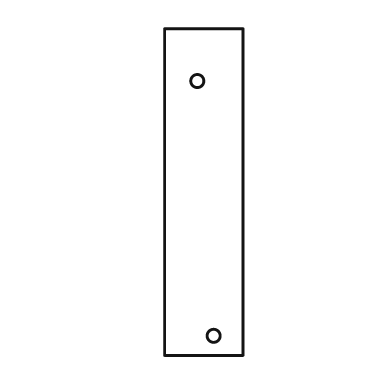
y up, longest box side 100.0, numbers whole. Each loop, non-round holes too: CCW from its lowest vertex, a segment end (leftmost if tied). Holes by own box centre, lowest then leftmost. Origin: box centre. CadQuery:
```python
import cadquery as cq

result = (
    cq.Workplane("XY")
    .moveTo(-12.0, -50.0)
    .lineTo(12.0, -50.0)
    .lineTo(12.0, 50.0)
    .lineTo(-12.0, 50.0)
    .close()
    .moveTo(3.0, -44.0)
    .circle(2.0)
    .moveTo(-2.0, 34.0)
    .circle(2.0)
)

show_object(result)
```